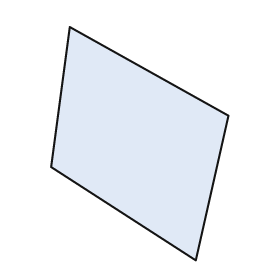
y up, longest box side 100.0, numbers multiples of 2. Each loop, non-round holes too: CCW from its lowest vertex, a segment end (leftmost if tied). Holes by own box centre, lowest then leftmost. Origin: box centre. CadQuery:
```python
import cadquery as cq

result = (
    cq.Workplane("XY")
    .moveTo(24.0, -50.0)
    .lineTo(38.0, 12.0)
    .lineTo(-30.0, 50.0)
    .lineTo(-38.0, -10.0)
    .close()
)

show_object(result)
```